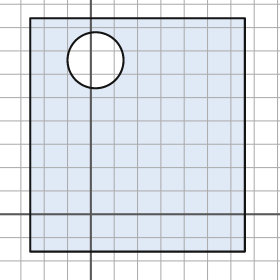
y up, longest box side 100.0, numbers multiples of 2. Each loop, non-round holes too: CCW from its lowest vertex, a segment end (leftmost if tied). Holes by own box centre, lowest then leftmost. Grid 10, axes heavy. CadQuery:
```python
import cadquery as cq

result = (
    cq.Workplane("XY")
    .moveTo(-26.0, -16.0)
    .lineTo(66.0, -16.0)
    .lineTo(66.0, 84.0)
    .lineTo(-26.0, 84.0)
    .close()
    .moveTo(2.0, 66.0)
    .circle(12.0)
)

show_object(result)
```